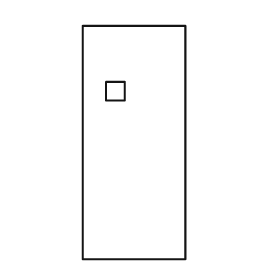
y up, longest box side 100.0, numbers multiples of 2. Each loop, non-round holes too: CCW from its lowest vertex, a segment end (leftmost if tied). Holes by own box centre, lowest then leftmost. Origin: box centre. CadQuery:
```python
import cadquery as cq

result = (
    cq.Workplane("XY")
    .moveTo(-22.0, -50.0)
    .lineTo(22.0, -50.0)
    .lineTo(22.0, 50.0)
    .lineTo(-22.0, 50.0)
    .close()
    .moveTo(-12.0, 18.0)
    .lineTo(-4.0, 18.0)
    .lineTo(-4.0, 26.0)
    .lineTo(-12.0, 26.0)
    .close()
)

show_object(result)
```